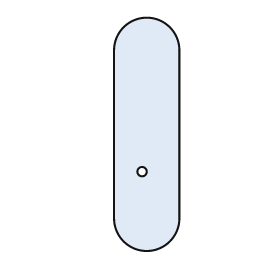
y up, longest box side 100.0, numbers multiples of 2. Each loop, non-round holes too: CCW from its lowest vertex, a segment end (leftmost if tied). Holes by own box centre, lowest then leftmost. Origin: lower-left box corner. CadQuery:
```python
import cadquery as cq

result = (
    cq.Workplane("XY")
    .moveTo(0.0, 14.0)
    .threePointArc((14.0, 0.0), (28.0, 14.0))
    .lineTo(28.0, 86.0)
    .threePointArc((14.0, 100.0), (0.0, 86.0))
    .close()
    .moveTo(12.0, 34.0)
    .circle(2.0)
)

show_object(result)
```